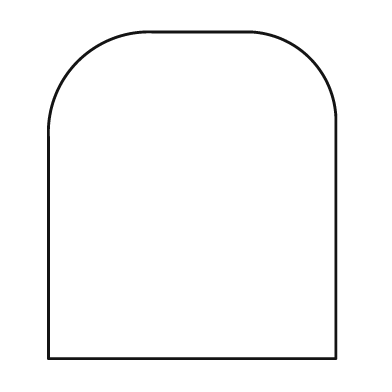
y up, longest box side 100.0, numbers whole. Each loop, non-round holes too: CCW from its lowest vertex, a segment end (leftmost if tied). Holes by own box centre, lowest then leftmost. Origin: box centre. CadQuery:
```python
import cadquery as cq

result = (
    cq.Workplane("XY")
    .moveTo(-44.0, -50.0)
    .lineTo(44.0, -50.0)
    .lineTo(44.0, 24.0)
    .threePointArc((36.0, 42.0), (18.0, 50.0))
    .lineTo(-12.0, 50.0)
    .threePointArc((-35.0, 41.0), (-44.0, 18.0))
    .close()
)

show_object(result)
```